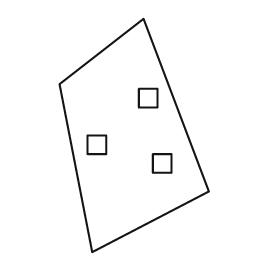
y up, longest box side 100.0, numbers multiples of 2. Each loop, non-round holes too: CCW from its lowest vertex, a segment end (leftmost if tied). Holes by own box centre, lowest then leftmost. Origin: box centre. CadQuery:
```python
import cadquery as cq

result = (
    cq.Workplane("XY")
    .moveTo(-18.0, -50.0)
    .lineTo(32.0, -24.0)
    .lineTo(4.0, 50.0)
    .lineTo(-32.0, 22.0)
    .close()
    .moveTo(8.0, -16.0)
    .lineTo(16.0, -16.0)
    .lineTo(16.0, -8.0)
    .lineTo(8.0, -8.0)
    .close()
    .moveTo(-20.0, -8.0)
    .lineTo(-12.0, -8.0)
    .lineTo(-12.0, 0.0)
    .lineTo(-20.0, 0.0)
    .close()
    .moveTo(2.0, 12.0)
    .lineTo(10.0, 12.0)
    .lineTo(10.0, 20.0)
    .lineTo(2.0, 20.0)
    .close()
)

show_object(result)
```